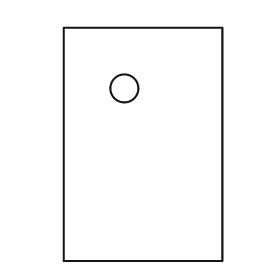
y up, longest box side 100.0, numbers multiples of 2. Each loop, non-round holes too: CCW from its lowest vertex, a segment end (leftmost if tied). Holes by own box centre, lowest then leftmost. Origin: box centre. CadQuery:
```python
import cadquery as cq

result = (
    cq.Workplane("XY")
    .moveTo(-34.0, -50.0)
    .lineTo(34.0, -50.0)
    .lineTo(34.0, 50.0)
    .lineTo(-34.0, 50.0)
    .close()
    .moveTo(-8.0, 24.0)
    .circle(6.0)
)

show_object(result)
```